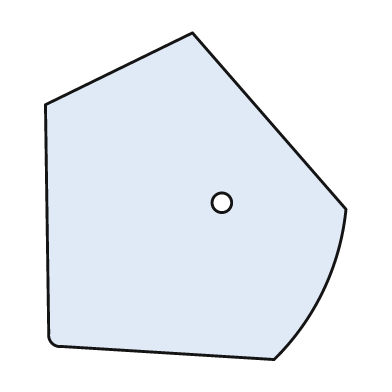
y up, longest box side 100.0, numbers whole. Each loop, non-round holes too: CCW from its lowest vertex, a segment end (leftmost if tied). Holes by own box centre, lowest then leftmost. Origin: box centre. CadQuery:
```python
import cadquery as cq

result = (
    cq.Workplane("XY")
    .moveTo(24.0, -50.0)
    .threePointArc((39.0, -29.0), (46.0, -4.0))
    .lineTo(-1.0, 50.0)
    .lineTo(-46.0, 28.0)
    .lineTo(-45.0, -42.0)
    .threePointArc((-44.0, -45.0), (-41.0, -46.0))
    .close()
    .moveTo(8.0, -2.0)
    .circle(3.0)
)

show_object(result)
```